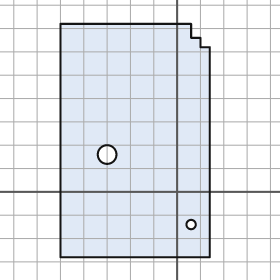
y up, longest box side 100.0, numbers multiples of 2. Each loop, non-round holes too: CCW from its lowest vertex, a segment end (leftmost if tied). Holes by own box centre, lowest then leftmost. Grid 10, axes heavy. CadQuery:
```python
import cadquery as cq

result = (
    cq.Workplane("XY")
    .moveTo(-50.0, -28.0)
    .lineTo(14.0, -28.0)
    .lineTo(14.0, 62.0)
    .lineTo(10.0, 62.0)
    .lineTo(10.0, 66.0)
    .lineTo(6.0, 66.0)
    .lineTo(6.0, 72.0)
    .lineTo(-50.0, 72.0)
    .close()
    .moveTo(6.0, -14.0)
    .circle(2.0)
    .moveTo(-30.0, 16.0)
    .circle(4.0)
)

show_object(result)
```